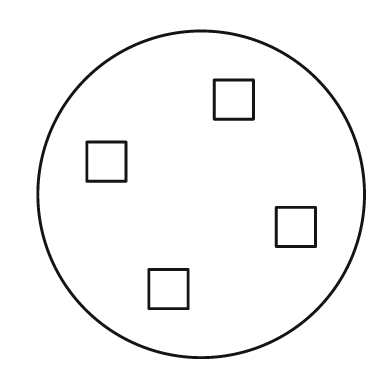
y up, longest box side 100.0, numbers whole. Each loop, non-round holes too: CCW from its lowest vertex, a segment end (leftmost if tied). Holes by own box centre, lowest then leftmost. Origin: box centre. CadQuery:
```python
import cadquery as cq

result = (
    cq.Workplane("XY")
    .moveTo(0.0, 0.0)
    .circle(50.0)
    .moveTo(-16.0, -35.0)
    .lineTo(-4.0, -35.0)
    .lineTo(-4.0, -23.0)
    .lineTo(-16.0, -23.0)
    .close()
    .moveTo(23.0, -16.0)
    .lineTo(35.0, -16.0)
    .lineTo(35.0, -4.0)
    .lineTo(23.0, -4.0)
    .close()
    .moveTo(-35.0, 4.0)
    .lineTo(-23.0, 4.0)
    .lineTo(-23.0, 16.0)
    .lineTo(-35.0, 16.0)
    .close()
    .moveTo(4.0, 23.0)
    .lineTo(16.0, 23.0)
    .lineTo(16.0, 35.0)
    .lineTo(4.0, 35.0)
    .close()
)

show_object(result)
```